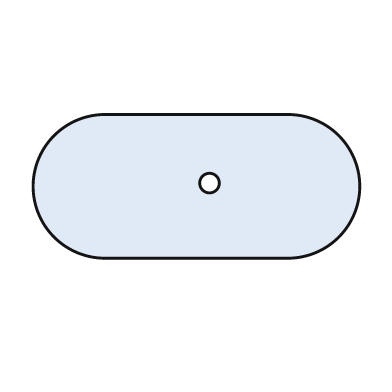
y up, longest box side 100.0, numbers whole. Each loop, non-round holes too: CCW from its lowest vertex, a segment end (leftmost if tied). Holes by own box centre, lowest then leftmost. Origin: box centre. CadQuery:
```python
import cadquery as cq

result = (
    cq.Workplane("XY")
    .moveTo(-28.0, -22.0)
    .lineTo(28.0, -22.0)
    .threePointArc((50.0, 0.0), (28.0, 22.0))
    .lineTo(-28.0, 22.0)
    .threePointArc((-50.0, 0.0), (-28.0, -22.0))
    .close()
    .moveTo(4.0, 1.0)
    .circle(3.0)
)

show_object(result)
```